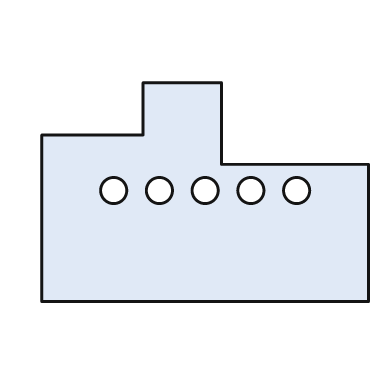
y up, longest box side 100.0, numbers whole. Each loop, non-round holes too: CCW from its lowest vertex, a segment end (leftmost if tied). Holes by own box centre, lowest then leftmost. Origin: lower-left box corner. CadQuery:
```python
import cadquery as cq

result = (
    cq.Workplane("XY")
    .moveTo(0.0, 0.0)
    .lineTo(100.0, 0.0)
    .lineTo(100.0, 42.0)
    .lineTo(55.0, 42.0)
    .lineTo(55.0, 67.0)
    .lineTo(31.0, 67.0)
    .lineTo(31.0, 51.0)
    .lineTo(0.0, 51.0)
    .close()
    .moveTo(22.0, 34.0)
    .circle(4.0)
    .moveTo(36.0, 34.0)
    .circle(4.0)
    .moveTo(50.0, 34.0)
    .circle(4.0)
    .moveTo(64.0, 34.0)
    .circle(4.0)
    .moveTo(78.0, 34.0)
    .circle(4.0)
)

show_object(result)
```